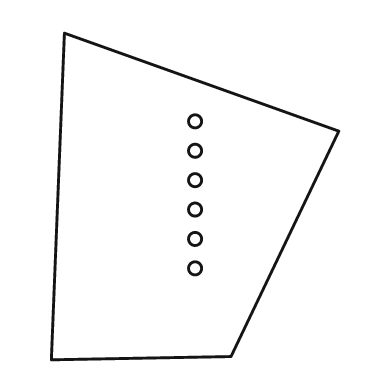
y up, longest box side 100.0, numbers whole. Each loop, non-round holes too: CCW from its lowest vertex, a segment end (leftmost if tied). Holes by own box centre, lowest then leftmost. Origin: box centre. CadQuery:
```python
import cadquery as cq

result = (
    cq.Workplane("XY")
    .moveTo(-44.0, -50.0)
    .lineTo(11.0, -49.0)
    .lineTo(44.0, 20.0)
    .lineTo(-40.0, 50.0)
    .close()
    .moveTo(0.0, -22.0)
    .circle(2.0)
    .moveTo(0.0, -13.0)
    .circle(2.0)
    .moveTo(0.0, -4.0)
    .circle(2.0)
    .moveTo(0.0, 5.0)
    .circle(2.0)
    .moveTo(0.0, 14.0)
    .circle(2.0)
    .moveTo(0.0, 23.0)
    .circle(2.0)
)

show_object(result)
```